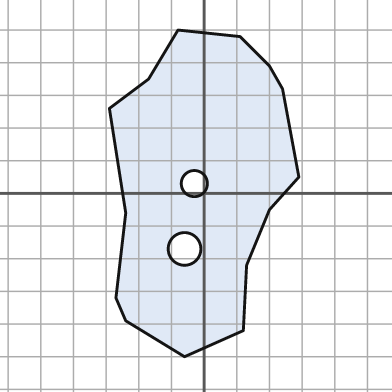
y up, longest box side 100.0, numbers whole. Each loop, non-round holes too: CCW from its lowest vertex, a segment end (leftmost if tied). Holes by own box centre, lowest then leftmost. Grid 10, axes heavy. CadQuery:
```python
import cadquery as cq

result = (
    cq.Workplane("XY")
    .moveTo(-6.0, -50.0)
    .lineTo(12.0, -42.0)
    .lineTo(13.0, -22.0)
    .lineTo(20.0, -5.0)
    .lineTo(29.0, 5.0)
    .lineTo(24.0, 32.0)
    .lineTo(20.0, 39.0)
    .lineTo(11.0, 48.0)
    .lineTo(-8.0, 50.0)
    .lineTo(-17.0, 35.0)
    .lineTo(-29.0, 26.0)
    .lineTo(-24.0, -6.0)
    .lineTo(-27.0, -32.0)
    .lineTo(-24.0, -39.0)
    .close()
    .moveTo(-6.0, -17.0)
    .circle(5.0)
    .moveTo(-3.0, 3.0)
    .circle(4.0)
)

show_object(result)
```